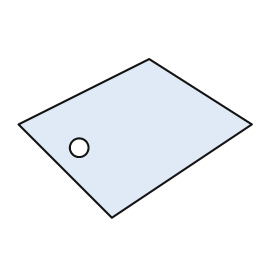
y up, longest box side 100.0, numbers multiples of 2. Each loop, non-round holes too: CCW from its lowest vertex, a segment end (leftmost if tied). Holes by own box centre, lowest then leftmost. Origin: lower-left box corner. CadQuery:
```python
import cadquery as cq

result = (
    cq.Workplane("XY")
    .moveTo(40.0, 0.0)
    .lineTo(100.0, 40.0)
    .lineTo(56.0, 68.0)
    .lineTo(0.0, 40.0)
    .close()
    .moveTo(26.0, 30.0)
    .circle(4.0)
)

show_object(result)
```